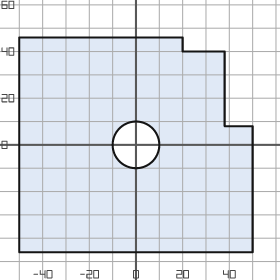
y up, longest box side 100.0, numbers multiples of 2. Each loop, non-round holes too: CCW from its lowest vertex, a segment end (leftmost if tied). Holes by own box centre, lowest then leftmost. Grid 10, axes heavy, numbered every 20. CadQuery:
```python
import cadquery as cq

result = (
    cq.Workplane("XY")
    .moveTo(-50.0, -46.0)
    .lineTo(50.0, -46.0)
    .lineTo(50.0, 8.0)
    .lineTo(38.0, 8.0)
    .lineTo(38.0, 40.0)
    .lineTo(20.0, 40.0)
    .lineTo(20.0, 46.0)
    .lineTo(-50.0, 46.0)
    .close()
    .moveTo(0.0, 0.0)
    .circle(10.0)
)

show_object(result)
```